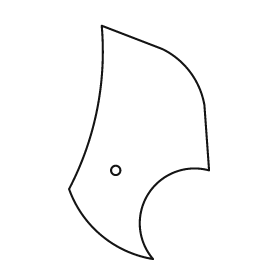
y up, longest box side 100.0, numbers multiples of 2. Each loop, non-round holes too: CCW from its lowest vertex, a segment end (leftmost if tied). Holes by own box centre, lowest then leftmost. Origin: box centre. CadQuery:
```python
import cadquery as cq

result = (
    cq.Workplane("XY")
    .moveTo(6.0, -50.0)
    .threePointArc((4.0, -22.0), (30.0, -12.0))
    .lineTo(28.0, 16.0)
    .threePointArc((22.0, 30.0), (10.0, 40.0))
    .lineTo(-16.0, 50.0)
    .threePointArc((-18.0, 14.0), (-30.0, -20.0))
    .threePointArc((-16.0, -40.0), (6.0, -50.0))
    .close()
    .moveTo(-10.0, -12.0)
    .circle(2.0)
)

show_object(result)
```